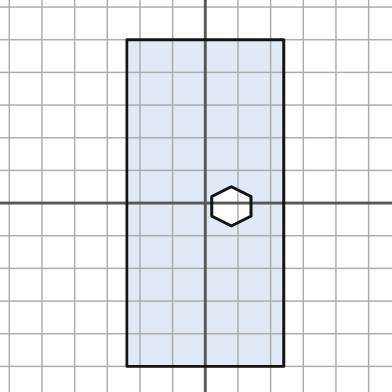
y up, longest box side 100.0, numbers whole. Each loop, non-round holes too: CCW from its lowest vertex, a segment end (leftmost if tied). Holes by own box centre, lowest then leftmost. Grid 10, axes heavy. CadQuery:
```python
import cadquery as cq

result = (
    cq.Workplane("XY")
    .moveTo(-24.0, -50.0)
    .lineTo(24.0, -50.0)
    .lineTo(24.0, 50.0)
    .lineTo(-24.0, 50.0)
    .close()
    .moveTo(8.0, -7.0)
    .lineTo(14.0, -4.0)
    .lineTo(14.0, 2.0)
    .lineTo(8.0, 5.0)
    .lineTo(2.0, 2.0)
    .lineTo(2.0, -4.0)
    .close()
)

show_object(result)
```